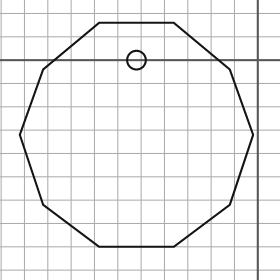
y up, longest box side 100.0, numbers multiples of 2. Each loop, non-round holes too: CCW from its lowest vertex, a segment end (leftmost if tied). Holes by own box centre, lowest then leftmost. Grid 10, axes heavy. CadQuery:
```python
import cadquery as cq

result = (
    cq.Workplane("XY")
    .moveTo(-68.0, -80.0)
    .lineTo(-36.0, -80.0)
    .lineTo(-12.0, -62.0)
    .lineTo(-2.0, -32.0)
    .lineTo(-12.0, -4.0)
    .lineTo(-36.0, 16.0)
    .lineTo(-68.0, 16.0)
    .lineTo(-92.0, -4.0)
    .lineTo(-102.0, -32.0)
    .lineTo(-92.0, -62.0)
    .close()
    .moveTo(-52.0, 0.0)
    .circle(4.0)
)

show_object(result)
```